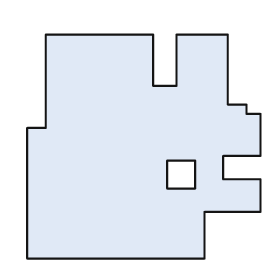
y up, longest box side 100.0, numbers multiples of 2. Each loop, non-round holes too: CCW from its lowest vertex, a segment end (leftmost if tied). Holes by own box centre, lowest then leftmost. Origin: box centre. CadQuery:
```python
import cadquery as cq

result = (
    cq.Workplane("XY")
    .moveTo(-50.0, -48.0)
    .lineTo(26.0, -48.0)
    .lineTo(26.0, -28.0)
    .lineTo(50.0, -28.0)
    .lineTo(50.0, -14.0)
    .lineTo(34.0, -14.0)
    .lineTo(34.0, -4.0)
    .lineTo(50.0, -4.0)
    .lineTo(50.0, 14.0)
    .lineTo(44.0, 14.0)
    .lineTo(44.0, 18.0)
    .lineTo(36.0, 18.0)
    .lineTo(36.0, 48.0)
    .lineTo(14.0, 48.0)
    .lineTo(14.0, 26.0)
    .lineTo(4.0, 26.0)
    .lineTo(4.0, 48.0)
    .lineTo(-42.0, 48.0)
    .lineTo(-42.0, 8.0)
    .lineTo(-50.0, 8.0)
    .close()
    .moveTo(10.0, -18.0)
    .lineTo(22.0, -18.0)
    .lineTo(22.0, -6.0)
    .lineTo(10.0, -6.0)
    .close()
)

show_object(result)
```